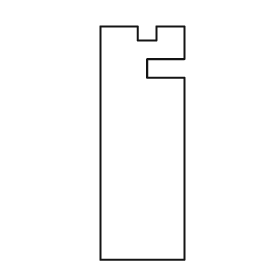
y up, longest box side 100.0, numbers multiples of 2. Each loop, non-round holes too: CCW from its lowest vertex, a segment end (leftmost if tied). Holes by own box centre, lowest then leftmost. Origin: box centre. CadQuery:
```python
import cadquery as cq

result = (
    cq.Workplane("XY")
    .moveTo(-18.0, -50.0)
    .lineTo(18.0, -50.0)
    .lineTo(18.0, 28.0)
    .lineTo(2.0, 28.0)
    .lineTo(2.0, 36.0)
    .lineTo(18.0, 36.0)
    .lineTo(18.0, 50.0)
    .lineTo(6.0, 50.0)
    .lineTo(6.0, 44.0)
    .lineTo(-2.0, 44.0)
    .lineTo(-2.0, 50.0)
    .lineTo(-18.0, 50.0)
    .close()
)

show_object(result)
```